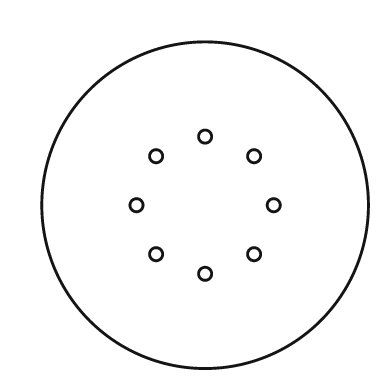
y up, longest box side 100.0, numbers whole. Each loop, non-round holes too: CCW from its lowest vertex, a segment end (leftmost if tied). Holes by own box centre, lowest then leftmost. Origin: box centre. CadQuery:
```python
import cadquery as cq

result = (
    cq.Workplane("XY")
    .moveTo(0.0, 0.0)
    .circle(50.0)
    .moveTo(0.0, -21.0)
    .circle(2.0)
    .moveTo(-15.0, -15.0)
    .circle(2.0)
    .moveTo(15.0, -15.0)
    .circle(2.0)
    .moveTo(-21.0, 0.0)
    .circle(2.0)
    .moveTo(21.0, 0.0)
    .circle(2.0)
    .moveTo(-15.0, 15.0)
    .circle(2.0)
    .moveTo(15.0, 15.0)
    .circle(2.0)
    .moveTo(0.0, 21.0)
    .circle(2.0)
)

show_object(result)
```